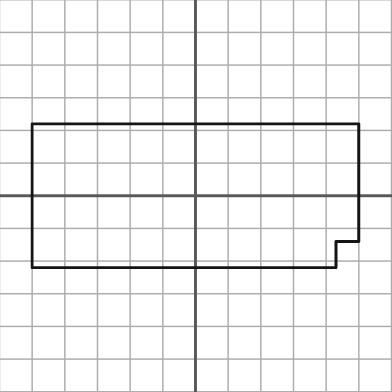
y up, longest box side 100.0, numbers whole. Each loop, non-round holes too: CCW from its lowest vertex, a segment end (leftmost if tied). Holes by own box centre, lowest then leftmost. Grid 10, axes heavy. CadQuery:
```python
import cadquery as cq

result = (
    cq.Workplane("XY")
    .moveTo(-50.0, -22.0)
    .lineTo(43.0, -22.0)
    .lineTo(43.0, -14.0)
    .lineTo(50.0, -14.0)
    .lineTo(50.0, 22.0)
    .lineTo(-50.0, 22.0)
    .close()
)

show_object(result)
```